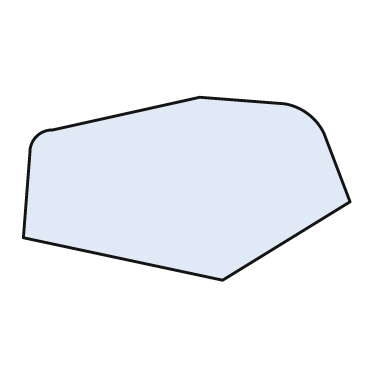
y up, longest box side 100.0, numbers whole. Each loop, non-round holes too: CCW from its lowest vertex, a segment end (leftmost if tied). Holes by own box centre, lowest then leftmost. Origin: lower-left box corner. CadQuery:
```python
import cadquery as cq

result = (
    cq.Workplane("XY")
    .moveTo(61.0, 0.0)
    .lineTo(100.0, 24.0)
    .lineTo(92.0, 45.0)
    .threePointArc((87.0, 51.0), (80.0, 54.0))
    .lineTo(54.0, 56.0)
    .lineTo(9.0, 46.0)
    .threePointArc((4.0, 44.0), (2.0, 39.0))
    .lineTo(0.0, 13.0)
    .close()
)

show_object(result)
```